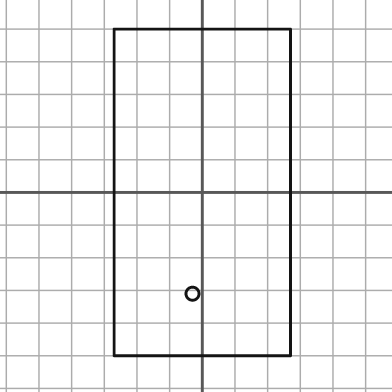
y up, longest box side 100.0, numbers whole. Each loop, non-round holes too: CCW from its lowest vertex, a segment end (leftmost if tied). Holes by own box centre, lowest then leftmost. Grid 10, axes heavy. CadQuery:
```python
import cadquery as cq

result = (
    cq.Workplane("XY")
    .moveTo(-27.0, -50.0)
    .lineTo(27.0, -50.0)
    .lineTo(27.0, 50.0)
    .lineTo(-27.0, 50.0)
    .close()
    .moveTo(-3.0, -31.0)
    .circle(2.0)
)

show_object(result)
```